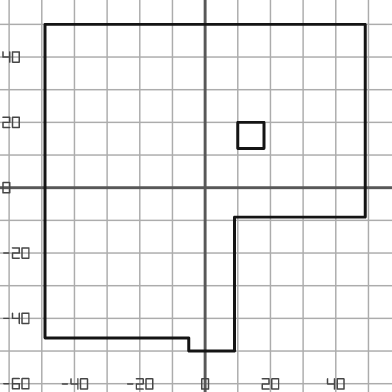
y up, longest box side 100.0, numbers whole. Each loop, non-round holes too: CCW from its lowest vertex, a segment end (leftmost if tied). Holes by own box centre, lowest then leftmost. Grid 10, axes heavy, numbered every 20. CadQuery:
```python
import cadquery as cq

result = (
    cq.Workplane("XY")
    .moveTo(-5.0, -50.0)
    .lineTo(9.0, -50.0)
    .lineTo(9.0, -9.0)
    .lineTo(49.0, -9.0)
    .lineTo(49.0, 50.0)
    .lineTo(-49.0, 50.0)
    .lineTo(-49.0, -46.0)
    .lineTo(-5.0, -46.0)
    .close()
    .moveTo(10.0, 12.0)
    .lineTo(18.0, 12.0)
    .lineTo(18.0, 20.0)
    .lineTo(10.0, 20.0)
    .close()
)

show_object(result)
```